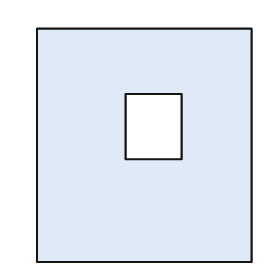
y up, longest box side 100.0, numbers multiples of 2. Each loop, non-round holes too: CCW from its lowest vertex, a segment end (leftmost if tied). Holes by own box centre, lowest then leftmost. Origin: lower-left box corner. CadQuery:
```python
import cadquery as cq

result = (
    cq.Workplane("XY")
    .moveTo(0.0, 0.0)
    .lineTo(92.0, 0.0)
    .lineTo(92.0, 100.0)
    .lineTo(0.0, 100.0)
    .close()
    .moveTo(38.0, 44.0)
    .lineTo(62.0, 44.0)
    .lineTo(62.0, 72.0)
    .lineTo(38.0, 72.0)
    .close()
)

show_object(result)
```